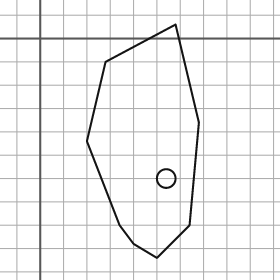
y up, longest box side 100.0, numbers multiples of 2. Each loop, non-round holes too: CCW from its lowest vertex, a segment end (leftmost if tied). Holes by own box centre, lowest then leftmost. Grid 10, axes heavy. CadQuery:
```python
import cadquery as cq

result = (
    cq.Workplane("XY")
    .moveTo(50.0, -94.0)
    .lineTo(64.0, -80.0)
    .lineTo(68.0, -36.0)
    .lineTo(58.0, 6.0)
    .lineTo(28.0, -10.0)
    .lineTo(20.0, -44.0)
    .lineTo(34.0, -80.0)
    .lineTo(40.0, -88.0)
    .close()
    .moveTo(54.0, -60.0)
    .circle(4.0)
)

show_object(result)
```